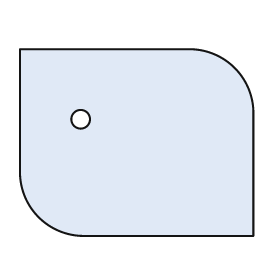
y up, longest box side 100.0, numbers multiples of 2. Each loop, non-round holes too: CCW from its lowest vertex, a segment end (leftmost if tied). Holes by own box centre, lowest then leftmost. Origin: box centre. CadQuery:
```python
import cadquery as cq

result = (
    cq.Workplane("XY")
    .moveTo(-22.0, -40.0)
    .lineTo(50.0, -40.0)
    .lineTo(50.0, 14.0)
    .threePointArc((42.0, 32.0), (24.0, 40.0))
    .lineTo(-50.0, 40.0)
    .lineTo(-50.0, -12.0)
    .threePointArc((-42.0, -32.0), (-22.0, -40.0))
    .close()
    .moveTo(-24.0, 10.0)
    .circle(4.0)
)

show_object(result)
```